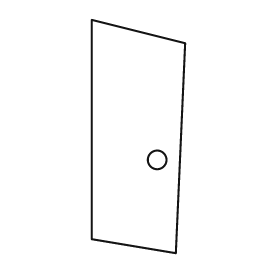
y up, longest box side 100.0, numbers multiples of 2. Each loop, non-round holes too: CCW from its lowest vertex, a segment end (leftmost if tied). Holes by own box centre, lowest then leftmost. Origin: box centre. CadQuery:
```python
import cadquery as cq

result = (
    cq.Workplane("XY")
    .moveTo(16.0, -50.0)
    .lineTo(20.0, 40.0)
    .lineTo(-20.0, 50.0)
    .lineTo(-20.0, -44.0)
    .close()
    .moveTo(8.0, -10.0)
    .circle(4.0)
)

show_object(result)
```